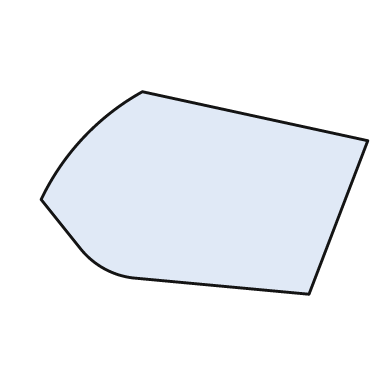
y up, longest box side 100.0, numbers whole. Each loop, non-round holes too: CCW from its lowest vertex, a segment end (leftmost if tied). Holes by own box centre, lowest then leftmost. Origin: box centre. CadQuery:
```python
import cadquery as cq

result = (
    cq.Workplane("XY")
    .moveTo(32.0, -31.0)
    .lineTo(50.0, 16.0)
    .lineTo(-19.0, 31.0)
    .threePointArc((-37.0, 17.0), (-50.0, -2.0))
    .lineTo(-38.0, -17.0)
    .threePointArc((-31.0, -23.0), (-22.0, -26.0))
    .close()
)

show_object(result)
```